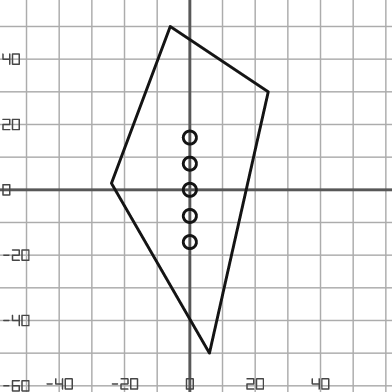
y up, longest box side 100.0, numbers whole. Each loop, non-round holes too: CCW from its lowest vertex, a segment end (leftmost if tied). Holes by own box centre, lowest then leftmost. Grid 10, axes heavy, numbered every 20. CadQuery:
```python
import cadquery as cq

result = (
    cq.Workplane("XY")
    .moveTo(6.0, -50.0)
    .lineTo(24.0, 30.0)
    .lineTo(-6.0, 50.0)
    .lineTo(-24.0, 2.0)
    .close()
    .moveTo(0.0, -16.0)
    .circle(2.0)
    .moveTo(0.0, -8.0)
    .circle(2.0)
    .moveTo(0.0, 0.0)
    .circle(2.0)
    .moveTo(0.0, 8.0)
    .circle(2.0)
    .moveTo(0.0, 16.0)
    .circle(2.0)
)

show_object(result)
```